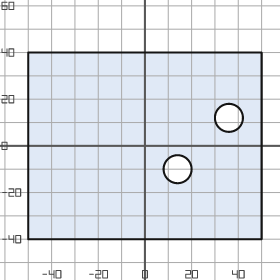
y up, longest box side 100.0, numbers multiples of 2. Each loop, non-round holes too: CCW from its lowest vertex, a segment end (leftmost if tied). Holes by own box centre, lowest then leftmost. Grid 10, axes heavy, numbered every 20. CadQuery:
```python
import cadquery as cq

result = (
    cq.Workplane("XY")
    .moveTo(-50.0, -40.0)
    .lineTo(50.0, -40.0)
    .lineTo(50.0, 40.0)
    .lineTo(-50.0, 40.0)
    .close()
    .moveTo(14.0, -10.0)
    .circle(6.0)
    .moveTo(36.0, 12.0)
    .circle(6.0)
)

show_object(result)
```